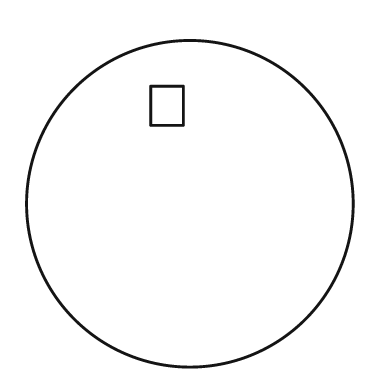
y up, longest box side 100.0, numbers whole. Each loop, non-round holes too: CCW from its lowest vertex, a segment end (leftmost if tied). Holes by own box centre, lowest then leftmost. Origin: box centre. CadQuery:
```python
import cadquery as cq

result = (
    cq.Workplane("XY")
    .moveTo(0.0, 0.0)
    .circle(50.0)
    .moveTo(-12.0, 24.0)
    .lineTo(-2.0, 24.0)
    .lineTo(-2.0, 36.0)
    .lineTo(-12.0, 36.0)
    .close()
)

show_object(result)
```